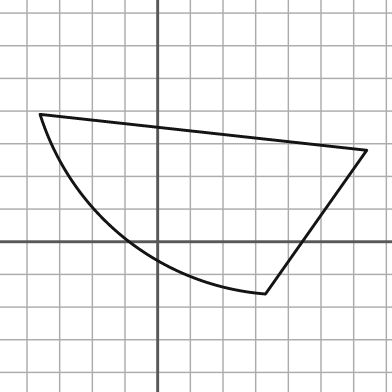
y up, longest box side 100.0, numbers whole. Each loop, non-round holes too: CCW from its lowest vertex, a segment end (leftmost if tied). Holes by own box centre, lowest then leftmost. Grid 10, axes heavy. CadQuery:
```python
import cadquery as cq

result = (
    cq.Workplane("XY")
    .moveTo(33.0, -16.0)
    .lineTo(64.0, 28.0)
    .lineTo(-36.0, 39.0)
    .threePointArc((-10.0, 1.0), (33.0, -16.0))
    .close()
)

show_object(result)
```